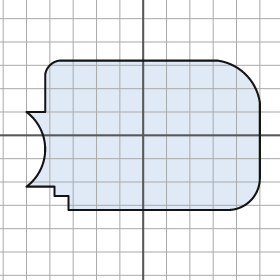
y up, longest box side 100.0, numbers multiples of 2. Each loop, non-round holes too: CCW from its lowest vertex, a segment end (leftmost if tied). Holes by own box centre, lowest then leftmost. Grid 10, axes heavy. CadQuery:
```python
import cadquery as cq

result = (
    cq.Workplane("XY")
    .moveTo(-32.0, -32.0)
    .lineTo(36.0, -32.0)
    .threePointArc((46.0, -28.0), (50.0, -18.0))
    .lineTo(50.0, 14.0)
    .threePointArc((44.0, 26.0), (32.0, 32.0))
    .lineTo(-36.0, 32.0)
    .threePointArc((-40.0, 30.0), (-42.0, 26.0))
    .lineTo(-42.0, 10.0)
    .lineTo(-50.0, 10.0)
    .threePointArc((-42.0, -6.0), (-50.0, -22.0))
    .lineTo(-38.0, -22.0)
    .lineTo(-38.0, -26.0)
    .lineTo(-32.0, -26.0)
    .close()
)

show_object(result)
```